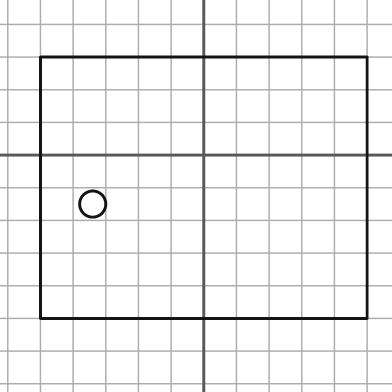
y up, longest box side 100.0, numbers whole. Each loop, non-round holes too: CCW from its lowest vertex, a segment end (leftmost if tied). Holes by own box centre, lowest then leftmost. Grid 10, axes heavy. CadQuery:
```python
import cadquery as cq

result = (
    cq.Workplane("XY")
    .moveTo(-50.0, -50.0)
    .lineTo(50.0, -50.0)
    .lineTo(50.0, 30.0)
    .lineTo(-50.0, 30.0)
    .close()
    .moveTo(-34.0, -15.0)
    .circle(4.0)
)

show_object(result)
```